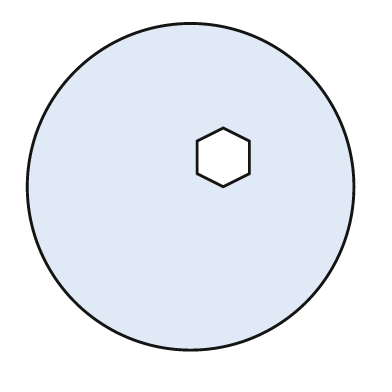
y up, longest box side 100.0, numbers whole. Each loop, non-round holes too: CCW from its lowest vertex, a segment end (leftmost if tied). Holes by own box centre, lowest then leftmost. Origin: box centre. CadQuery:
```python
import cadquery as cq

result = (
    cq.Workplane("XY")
    .moveTo(0.0, 0.0)
    .circle(50.0)
    .moveTo(10.0, 0.0)
    .lineTo(18.0, 4.0)
    .lineTo(18.0, 14.0)
    .lineTo(10.0, 18.0)
    .lineTo(2.0, 14.0)
    .lineTo(2.0, 4.0)
    .close()
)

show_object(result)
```